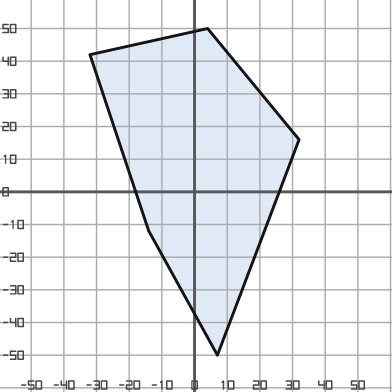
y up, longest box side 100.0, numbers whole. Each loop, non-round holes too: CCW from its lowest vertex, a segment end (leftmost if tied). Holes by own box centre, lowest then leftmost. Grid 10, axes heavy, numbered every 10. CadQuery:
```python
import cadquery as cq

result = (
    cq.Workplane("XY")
    .moveTo(7.0, -50.0)
    .lineTo(32.0, 16.0)
    .lineTo(4.0, 50.0)
    .lineTo(-32.0, 42.0)
    .lineTo(-14.0, -12.0)
    .close()
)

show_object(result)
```